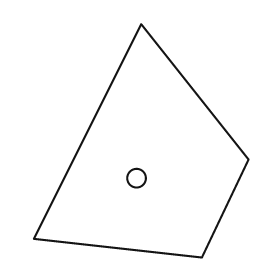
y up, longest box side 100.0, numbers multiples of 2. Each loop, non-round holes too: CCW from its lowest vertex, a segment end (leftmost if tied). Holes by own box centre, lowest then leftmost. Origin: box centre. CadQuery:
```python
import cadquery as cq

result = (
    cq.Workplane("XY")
    .moveTo(26.0, -50.0)
    .lineTo(46.0, -8.0)
    .lineTo(0.0, 50.0)
    .lineTo(-46.0, -42.0)
    .close()
    .moveTo(-2.0, -16.0)
    .circle(4.0)
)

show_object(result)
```